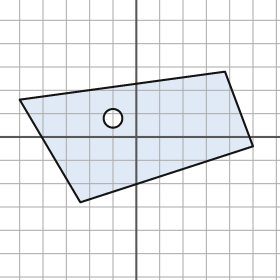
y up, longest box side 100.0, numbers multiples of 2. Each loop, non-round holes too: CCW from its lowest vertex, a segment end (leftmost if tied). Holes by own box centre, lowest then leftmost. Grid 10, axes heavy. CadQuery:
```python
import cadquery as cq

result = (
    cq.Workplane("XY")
    .moveTo(-24.0, -28.0)
    .lineTo(50.0, -4.0)
    .lineTo(38.0, 28.0)
    .lineTo(-50.0, 16.0)
    .close()
    .moveTo(-10.0, 8.0)
    .circle(4.0)
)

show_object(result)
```